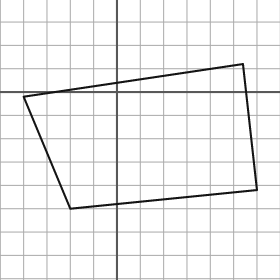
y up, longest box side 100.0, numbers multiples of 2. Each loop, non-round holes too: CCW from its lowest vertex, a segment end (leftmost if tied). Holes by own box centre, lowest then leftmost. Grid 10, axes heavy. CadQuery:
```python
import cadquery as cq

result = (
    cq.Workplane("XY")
    .moveTo(-20.0, -50.0)
    .lineTo(60.0, -42.0)
    .lineTo(54.0, 12.0)
    .lineTo(-40.0, -2.0)
    .close()
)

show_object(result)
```